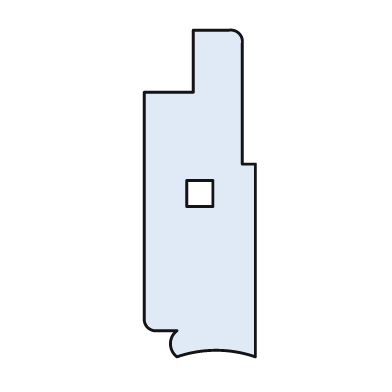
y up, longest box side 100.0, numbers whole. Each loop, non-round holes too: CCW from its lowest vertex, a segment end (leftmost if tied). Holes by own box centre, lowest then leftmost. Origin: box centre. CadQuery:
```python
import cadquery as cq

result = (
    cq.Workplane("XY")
    .moveTo(-7.0, -50.0)
    .threePointArc((5.0, -48.0), (17.0, -50.0))
    .lineTo(17.0, 9.0)
    .lineTo(13.0, 9.0)
    .lineTo(13.0, 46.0)
    .threePointArc((12.0, 49.0), (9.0, 50.0))
    .lineTo(-2.0, 50.0)
    .lineTo(-2.0, 31.0)
    .lineTo(-17.0, 31.0)
    .lineTo(-17.0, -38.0)
    .threePointArc((-16.0, -41.0), (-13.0, -42.0))
    .lineTo(-7.0, -42.0)
    .threePointArc((-9.0, -46.0), (-7.0, -50.0))
    .close()
    .moveTo(-4.0, -4.0)
    .lineTo(4.0, -4.0)
    .lineTo(4.0, 4.0)
    .lineTo(-4.0, 4.0)
    .close()
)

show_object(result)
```